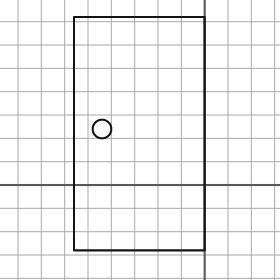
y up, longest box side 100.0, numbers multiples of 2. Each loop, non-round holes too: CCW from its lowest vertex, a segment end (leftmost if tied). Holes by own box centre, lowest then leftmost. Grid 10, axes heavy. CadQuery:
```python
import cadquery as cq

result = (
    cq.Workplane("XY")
    .moveTo(-56.0, -28.0)
    .lineTo(0.0, -28.0)
    .lineTo(0.0, 72.0)
    .lineTo(-56.0, 72.0)
    .close()
    .moveTo(-44.0, 24.0)
    .circle(4.0)
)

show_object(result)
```